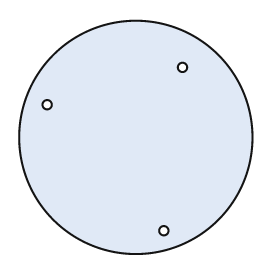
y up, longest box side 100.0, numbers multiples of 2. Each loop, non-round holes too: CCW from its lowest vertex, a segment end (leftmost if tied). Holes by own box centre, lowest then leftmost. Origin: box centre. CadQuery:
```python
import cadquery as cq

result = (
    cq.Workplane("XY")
    .moveTo(0.0, 0.0)
    .circle(50.0)
    .moveTo(12.0, -40.0)
    .circle(2.0)
    .moveTo(-38.0, 14.0)
    .circle(2.0)
    .moveTo(20.0, 30.0)
    .circle(2.0)
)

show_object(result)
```